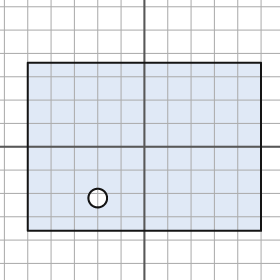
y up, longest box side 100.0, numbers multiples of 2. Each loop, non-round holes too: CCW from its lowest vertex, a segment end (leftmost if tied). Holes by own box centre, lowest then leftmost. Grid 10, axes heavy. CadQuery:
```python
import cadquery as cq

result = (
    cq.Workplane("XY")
    .moveTo(-50.0, -36.0)
    .lineTo(50.0, -36.0)
    .lineTo(50.0, 36.0)
    .lineTo(-50.0, 36.0)
    .close()
    .moveTo(-20.0, -22.0)
    .circle(4.0)
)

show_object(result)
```